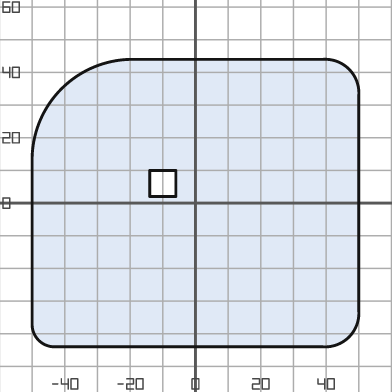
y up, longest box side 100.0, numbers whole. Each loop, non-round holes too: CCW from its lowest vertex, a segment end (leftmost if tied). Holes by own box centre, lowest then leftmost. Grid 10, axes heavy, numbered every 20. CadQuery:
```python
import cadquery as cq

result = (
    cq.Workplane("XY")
    .moveTo(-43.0, -44.0)
    .lineTo(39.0, -44.0)
    .threePointArc((47.0, -41.0), (50.0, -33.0))
    .lineTo(50.0, 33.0)
    .threePointArc((47.0, 41.0), (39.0, 44.0))
    .lineTo(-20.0, 44.0)
    .threePointArc((-41.0, 35.0), (-50.0, 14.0))
    .lineTo(-50.0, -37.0)
    .threePointArc((-48.0, -42.0), (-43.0, -44.0))
    .close()
    .moveTo(-14.0, 2.0)
    .lineTo(-6.0, 2.0)
    .lineTo(-6.0, 10.0)
    .lineTo(-14.0, 10.0)
    .close()
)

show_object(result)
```